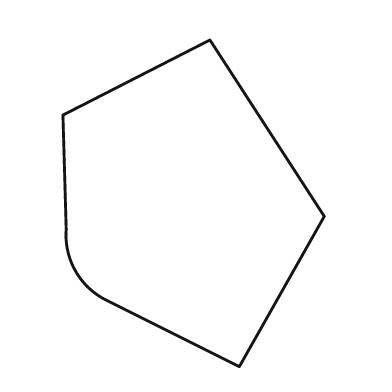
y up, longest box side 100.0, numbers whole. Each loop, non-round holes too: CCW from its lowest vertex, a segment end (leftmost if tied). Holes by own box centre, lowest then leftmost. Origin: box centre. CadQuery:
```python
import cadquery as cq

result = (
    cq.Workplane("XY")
    .moveTo(14.0, -50.0)
    .lineTo(40.0, -4.0)
    .lineTo(5.0, 50.0)
    .lineTo(-40.0, 27.0)
    .lineTo(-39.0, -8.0)
    .threePointArc((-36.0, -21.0), (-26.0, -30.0))
    .close()
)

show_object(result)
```